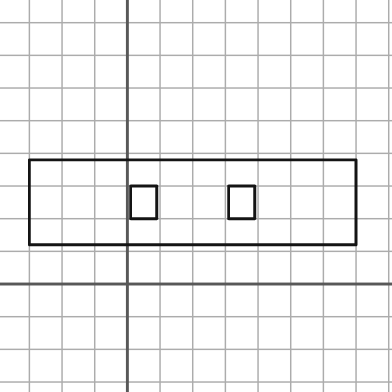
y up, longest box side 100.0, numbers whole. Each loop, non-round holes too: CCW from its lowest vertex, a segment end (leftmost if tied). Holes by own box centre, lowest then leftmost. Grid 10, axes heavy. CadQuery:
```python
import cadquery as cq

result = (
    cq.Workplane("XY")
    .moveTo(-30.0, 12.0)
    .lineTo(70.0, 12.0)
    .lineTo(70.0, 38.0)
    .lineTo(-30.0, 38.0)
    .close()
    .moveTo(1.0, 20.0)
    .lineTo(9.0, 20.0)
    .lineTo(9.0, 30.0)
    .lineTo(1.0, 30.0)
    .close()
    .moveTo(31.0, 20.0)
    .lineTo(39.0, 20.0)
    .lineTo(39.0, 30.0)
    .lineTo(31.0, 30.0)
    .close()
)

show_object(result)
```